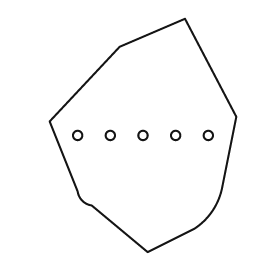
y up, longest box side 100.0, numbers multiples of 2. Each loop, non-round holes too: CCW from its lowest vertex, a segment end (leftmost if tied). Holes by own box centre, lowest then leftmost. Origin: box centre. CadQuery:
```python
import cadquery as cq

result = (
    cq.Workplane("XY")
    .moveTo(2.0, -50.0)
    .lineTo(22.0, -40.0)
    .threePointArc((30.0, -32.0), (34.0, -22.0))
    .lineTo(40.0, 8.0)
    .lineTo(18.0, 50.0)
    .lineTo(-10.0, 38.0)
    .lineTo(-40.0, 6.0)
    .lineTo(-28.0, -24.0)
    .threePointArc((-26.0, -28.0), (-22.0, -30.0))
    .close()
    .moveTo(-28.0, 0.0)
    .circle(2.0)
    .moveTo(-14.0, 0.0)
    .circle(2.0)
    .moveTo(0.0, 0.0)
    .circle(2.0)
    .moveTo(14.0, 0.0)
    .circle(2.0)
    .moveTo(28.0, 0.0)
    .circle(2.0)
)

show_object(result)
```